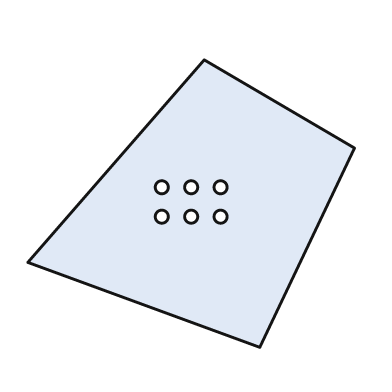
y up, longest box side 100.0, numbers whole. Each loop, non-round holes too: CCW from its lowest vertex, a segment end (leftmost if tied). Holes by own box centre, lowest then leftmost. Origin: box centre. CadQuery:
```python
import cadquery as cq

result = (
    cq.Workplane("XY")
    .moveTo(21.0, -44.0)
    .lineTo(50.0, 17.0)
    .lineTo(4.0, 44.0)
    .lineTo(-50.0, -18.0)
    .close()
    .moveTo(-9.0, -4.0)
    .circle(2.0)
    .moveTo(0.0, -4.0)
    .circle(2.0)
    .moveTo(9.0, -4.0)
    .circle(2.0)
    .moveTo(-9.0, 5.0)
    .circle(2.0)
    .moveTo(0.0, 5.0)
    .circle(2.0)
    .moveTo(9.0, 5.0)
    .circle(2.0)
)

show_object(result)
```